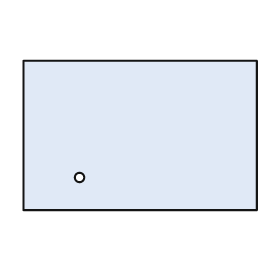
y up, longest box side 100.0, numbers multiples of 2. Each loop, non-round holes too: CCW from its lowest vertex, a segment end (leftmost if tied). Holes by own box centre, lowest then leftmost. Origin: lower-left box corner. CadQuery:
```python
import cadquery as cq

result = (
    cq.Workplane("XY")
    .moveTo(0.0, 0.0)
    .lineTo(100.0, 0.0)
    .lineTo(100.0, 64.0)
    .lineTo(0.0, 64.0)
    .close()
    .moveTo(24.0, 14.0)
    .circle(2.0)
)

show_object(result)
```